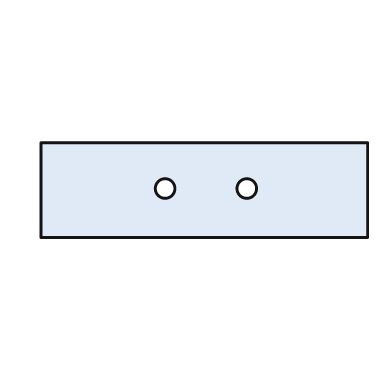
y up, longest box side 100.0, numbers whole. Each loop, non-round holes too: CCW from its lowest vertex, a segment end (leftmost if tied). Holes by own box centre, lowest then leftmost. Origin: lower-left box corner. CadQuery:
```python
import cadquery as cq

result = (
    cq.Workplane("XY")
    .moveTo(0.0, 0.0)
    .lineTo(100.0, 0.0)
    .lineTo(100.0, 29.0)
    .lineTo(0.0, 29.0)
    .close()
    .moveTo(38.0, 15.0)
    .circle(3.0)
    .moveTo(63.0, 15.0)
    .circle(3.0)
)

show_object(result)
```